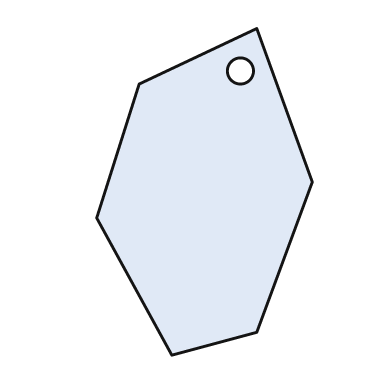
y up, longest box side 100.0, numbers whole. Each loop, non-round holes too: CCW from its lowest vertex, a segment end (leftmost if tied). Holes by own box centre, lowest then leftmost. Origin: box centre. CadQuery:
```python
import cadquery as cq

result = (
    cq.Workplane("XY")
    .moveTo(-10.0, -50.0)
    .lineTo(16.0, -43.0)
    .lineTo(33.0, 3.0)
    .lineTo(16.0, 50.0)
    .lineTo(-20.0, 33.0)
    .lineTo(-33.0, -8.0)
    .close()
    .moveTo(11.0, 37.0)
    .circle(4.0)
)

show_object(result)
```